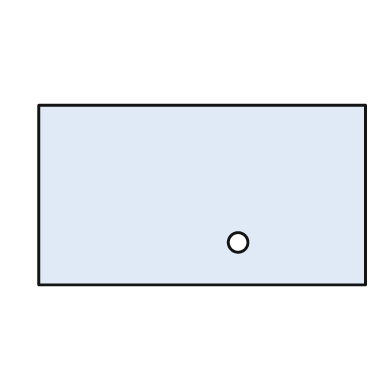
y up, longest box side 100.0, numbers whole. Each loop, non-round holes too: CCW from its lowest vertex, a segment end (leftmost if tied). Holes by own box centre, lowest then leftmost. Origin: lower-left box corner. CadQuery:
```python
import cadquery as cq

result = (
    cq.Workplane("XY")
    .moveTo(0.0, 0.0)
    .lineTo(100.0, 0.0)
    .lineTo(100.0, 55.0)
    .lineTo(0.0, 55.0)
    .close()
    .moveTo(61.0, 13.0)
    .circle(3.0)
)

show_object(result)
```